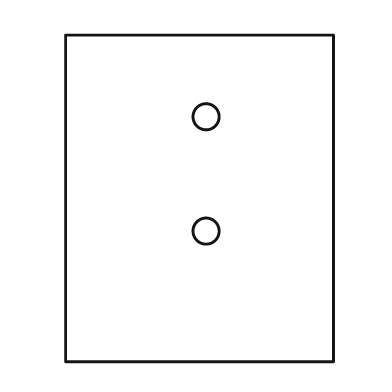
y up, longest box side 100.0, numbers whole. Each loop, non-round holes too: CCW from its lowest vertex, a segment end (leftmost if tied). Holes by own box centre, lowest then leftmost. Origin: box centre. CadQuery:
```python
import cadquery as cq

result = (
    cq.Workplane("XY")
    .moveTo(-41.0, -50.0)
    .lineTo(41.0, -50.0)
    .lineTo(41.0, 50.0)
    .lineTo(-41.0, 50.0)
    .close()
    .moveTo(2.0, -10.0)
    .circle(4.0)
    .moveTo(2.0, 25.0)
    .circle(4.0)
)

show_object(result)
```